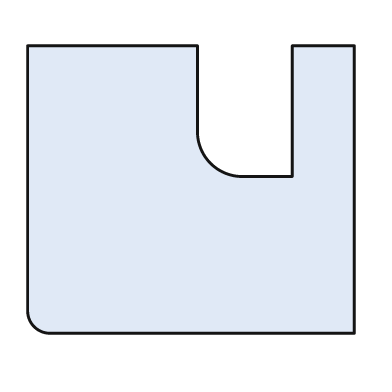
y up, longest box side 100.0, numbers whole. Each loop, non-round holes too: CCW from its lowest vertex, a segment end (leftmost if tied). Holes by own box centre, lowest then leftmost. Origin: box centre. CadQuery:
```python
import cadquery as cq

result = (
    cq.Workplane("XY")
    .moveTo(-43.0, -44.0)
    .lineTo(50.0, -44.0)
    .lineTo(50.0, 44.0)
    .lineTo(31.0, 44.0)
    .lineTo(31.0, 4.0)
    .lineTo(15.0, 4.0)
    .threePointArc((6.0, 8.0), (2.0, 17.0))
    .lineTo(2.0, 44.0)
    .lineTo(-50.0, 44.0)
    .lineTo(-50.0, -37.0)
    .threePointArc((-48.0, -42.0), (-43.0, -44.0))
    .close()
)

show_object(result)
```